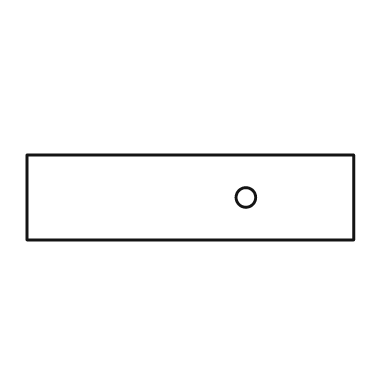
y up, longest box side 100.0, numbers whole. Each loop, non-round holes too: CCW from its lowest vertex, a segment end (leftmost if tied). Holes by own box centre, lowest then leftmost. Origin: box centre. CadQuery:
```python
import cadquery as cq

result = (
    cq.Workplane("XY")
    .moveTo(-50.0, -13.0)
    .lineTo(50.0, -13.0)
    .lineTo(50.0, 13.0)
    .lineTo(-50.0, 13.0)
    .close()
    .moveTo(17.0, 0.0)
    .circle(3.0)
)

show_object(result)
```